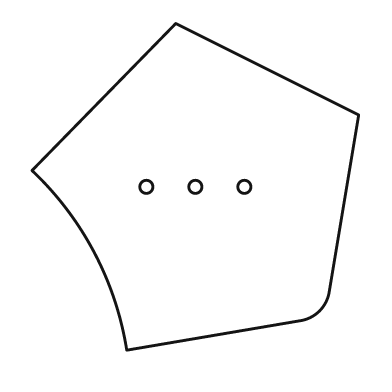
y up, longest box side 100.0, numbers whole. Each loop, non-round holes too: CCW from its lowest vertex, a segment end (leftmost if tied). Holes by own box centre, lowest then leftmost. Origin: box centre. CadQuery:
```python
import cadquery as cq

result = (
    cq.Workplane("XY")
    .moveTo(-21.0, -50.0)
    .lineTo(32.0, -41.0)
    .threePointArc((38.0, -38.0), (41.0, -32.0))
    .lineTo(50.0, 22.0)
    .lineTo(-6.0, 50.0)
    .lineTo(-50.0, 5.0)
    .threePointArc((-31.0, -20.0), (-21.0, -50.0))
    .close()
    .moveTo(-15.0, 0.0)
    .circle(2.0)
    .moveTo(0.0, 0.0)
    .circle(2.0)
    .moveTo(15.0, 0.0)
    .circle(2.0)
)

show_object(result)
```